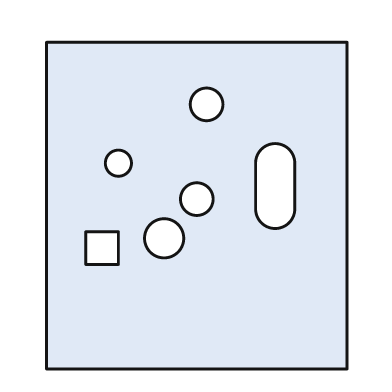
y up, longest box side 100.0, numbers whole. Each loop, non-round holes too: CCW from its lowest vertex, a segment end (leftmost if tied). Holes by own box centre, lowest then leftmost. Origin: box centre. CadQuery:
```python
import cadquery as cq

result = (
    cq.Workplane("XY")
    .moveTo(-46.0, -50.0)
    .lineTo(46.0, -50.0)
    .lineTo(46.0, 50.0)
    .lineTo(-46.0, 50.0)
    .close()
    .moveTo(-34.0, -18.0)
    .lineTo(-24.0, -18.0)
    .lineTo(-24.0, -8.0)
    .lineTo(-34.0, -8.0)
    .close()
    .moveTo(-10.0, -10.0)
    .circle(6.0)
    .moveTo(0.0, 2.0)
    .circle(5.0)
    .moveTo(18.0, -1.0)
    .threePointArc((24.0, -7.0), (30.0, -1.0))
    .lineTo(30.0, 13.0)
    .threePointArc((24.0, 19.0), (18.0, 13.0))
    .close()
    .moveTo(-24.0, 13.0)
    .circle(4.0)
    .moveTo(3.0, 31.0)
    .circle(5.0)
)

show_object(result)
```